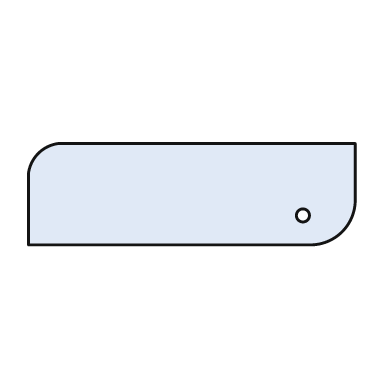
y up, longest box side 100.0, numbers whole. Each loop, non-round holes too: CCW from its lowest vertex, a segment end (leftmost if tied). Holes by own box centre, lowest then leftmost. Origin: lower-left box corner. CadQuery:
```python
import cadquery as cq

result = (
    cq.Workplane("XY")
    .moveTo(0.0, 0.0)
    .lineTo(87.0, 0.0)
    .threePointArc((96.0, 4.0), (100.0, 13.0))
    .lineTo(100.0, 31.0)
    .lineTo(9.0, 31.0)
    .threePointArc((3.0, 28.0), (0.0, 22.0))
    .close()
    .moveTo(84.0, 9.0)
    .circle(2.0)
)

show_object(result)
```